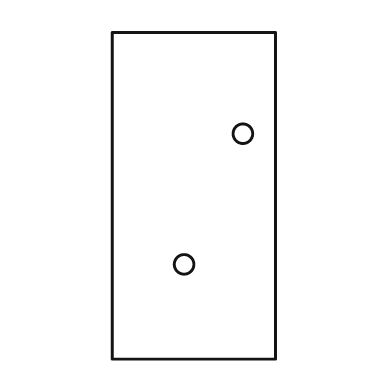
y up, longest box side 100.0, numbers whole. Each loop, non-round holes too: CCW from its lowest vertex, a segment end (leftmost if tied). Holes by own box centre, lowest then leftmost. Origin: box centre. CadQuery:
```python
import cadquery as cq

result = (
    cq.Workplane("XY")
    .moveTo(-25.0, -50.0)
    .lineTo(25.0, -50.0)
    .lineTo(25.0, 50.0)
    .lineTo(-25.0, 50.0)
    .close()
    .moveTo(-3.0, -21.0)
    .circle(3.0)
    .moveTo(15.0, 19.0)
    .circle(3.0)
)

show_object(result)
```